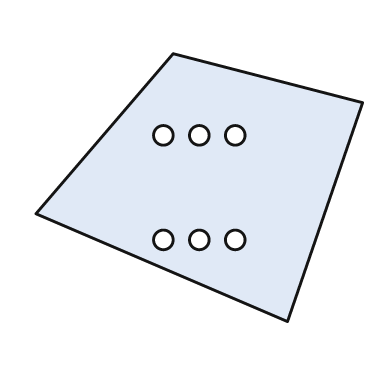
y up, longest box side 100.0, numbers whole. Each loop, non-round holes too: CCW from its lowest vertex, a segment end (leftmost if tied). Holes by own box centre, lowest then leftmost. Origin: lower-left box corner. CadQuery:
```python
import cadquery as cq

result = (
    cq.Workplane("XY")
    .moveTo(77.0, 0.0)
    .lineTo(100.0, 67.0)
    .lineTo(42.0, 82.0)
    .lineTo(0.0, 33.0)
    .close()
    .moveTo(39.0, 25.0)
    .circle(3.0)
    .moveTo(50.0, 25.0)
    .circle(3.0)
    .moveTo(61.0, 25.0)
    .circle(3.0)
    .moveTo(39.0, 57.0)
    .circle(3.0)
    .moveTo(50.0, 57.0)
    .circle(3.0)
    .moveTo(61.0, 57.0)
    .circle(3.0)
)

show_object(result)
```